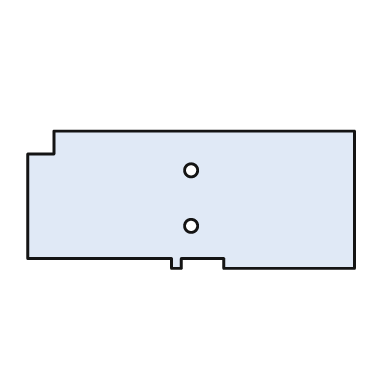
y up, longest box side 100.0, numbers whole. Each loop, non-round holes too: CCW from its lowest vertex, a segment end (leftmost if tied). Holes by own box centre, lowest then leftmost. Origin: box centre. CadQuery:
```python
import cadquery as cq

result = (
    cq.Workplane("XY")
    .moveTo(-6.0, -21.0)
    .lineTo(-3.0, -21.0)
    .lineTo(-3.0, -18.0)
    .lineTo(10.0, -18.0)
    .lineTo(10.0, -21.0)
    .lineTo(50.0, -21.0)
    .lineTo(50.0, 21.0)
    .lineTo(-42.0, 21.0)
    .lineTo(-42.0, 14.0)
    .lineTo(-50.0, 14.0)
    .lineTo(-50.0, -18.0)
    .lineTo(-6.0, -18.0)
    .close()
    .moveTo(0.0, -8.0)
    .circle(2.0)
    .moveTo(0.0, 9.0)
    .circle(2.0)
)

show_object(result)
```